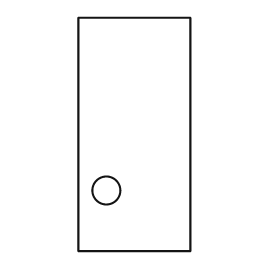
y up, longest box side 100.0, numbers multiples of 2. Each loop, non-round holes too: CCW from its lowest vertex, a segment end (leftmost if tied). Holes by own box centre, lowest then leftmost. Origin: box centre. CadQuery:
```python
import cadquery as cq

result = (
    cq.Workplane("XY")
    .moveTo(-24.0, -50.0)
    .lineTo(24.0, -50.0)
    .lineTo(24.0, 50.0)
    .lineTo(-24.0, 50.0)
    .close()
    .moveTo(-12.0, -24.0)
    .circle(6.0)
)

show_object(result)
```